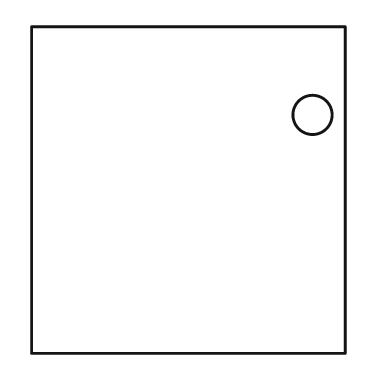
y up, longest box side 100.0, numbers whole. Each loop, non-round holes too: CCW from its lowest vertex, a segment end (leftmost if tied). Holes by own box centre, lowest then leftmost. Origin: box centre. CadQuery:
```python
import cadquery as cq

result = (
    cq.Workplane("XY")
    .moveTo(-48.0, -50.0)
    .lineTo(48.0, -50.0)
    .lineTo(48.0, 50.0)
    .lineTo(-48.0, 50.0)
    .close()
    .moveTo(38.0, 23.0)
    .circle(6.0)
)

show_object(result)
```